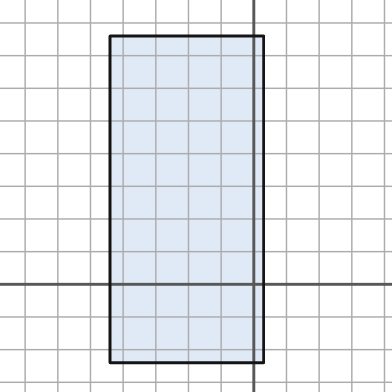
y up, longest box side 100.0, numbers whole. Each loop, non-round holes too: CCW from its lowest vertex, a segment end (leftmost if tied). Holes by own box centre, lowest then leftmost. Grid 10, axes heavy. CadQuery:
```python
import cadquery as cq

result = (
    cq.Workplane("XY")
    .moveTo(-44.0, -24.0)
    .lineTo(3.0, -24.0)
    .lineTo(3.0, 76.0)
    .lineTo(-44.0, 76.0)
    .close()
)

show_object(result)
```